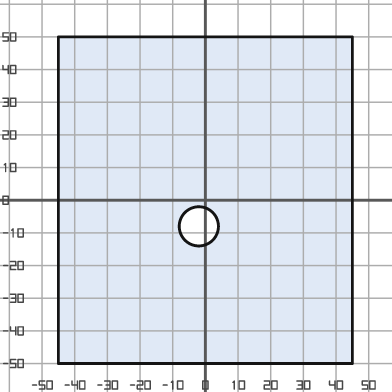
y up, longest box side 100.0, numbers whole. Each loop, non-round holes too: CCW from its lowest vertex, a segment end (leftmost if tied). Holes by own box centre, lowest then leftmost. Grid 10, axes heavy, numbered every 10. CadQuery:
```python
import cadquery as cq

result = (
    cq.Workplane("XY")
    .moveTo(-45.0, -50.0)
    .lineTo(45.0, -50.0)
    .lineTo(45.0, 50.0)
    .lineTo(-45.0, 50.0)
    .close()
    .moveTo(-2.0, -8.0)
    .circle(6.0)
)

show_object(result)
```